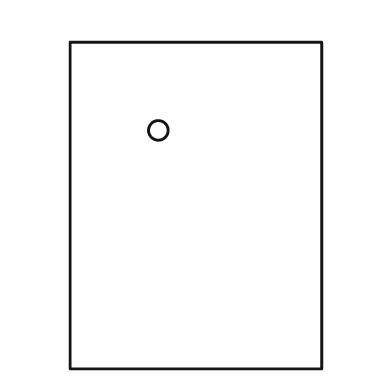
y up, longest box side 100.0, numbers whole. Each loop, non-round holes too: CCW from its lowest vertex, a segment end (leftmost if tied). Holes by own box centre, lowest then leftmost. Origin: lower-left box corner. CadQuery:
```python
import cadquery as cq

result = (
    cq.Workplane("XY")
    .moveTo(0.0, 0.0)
    .lineTo(77.0, 0.0)
    .lineTo(77.0, 100.0)
    .lineTo(0.0, 100.0)
    .close()
    .moveTo(27.0, 73.0)
    .circle(3.0)
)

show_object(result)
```